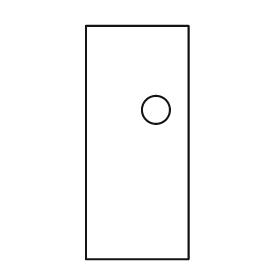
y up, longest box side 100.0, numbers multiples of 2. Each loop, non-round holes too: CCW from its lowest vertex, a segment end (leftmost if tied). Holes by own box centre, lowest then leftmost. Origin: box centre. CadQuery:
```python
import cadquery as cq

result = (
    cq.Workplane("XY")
    .moveTo(-22.0, -50.0)
    .lineTo(22.0, -50.0)
    .lineTo(22.0, 50.0)
    .lineTo(-22.0, 50.0)
    .close()
    .moveTo(8.0, 14.0)
    .circle(6.0)
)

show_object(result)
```